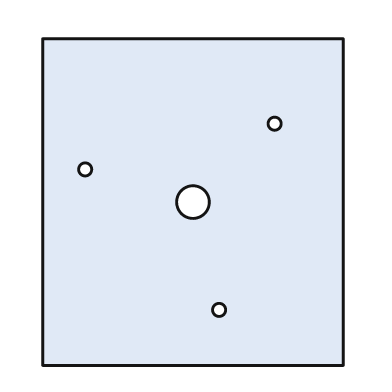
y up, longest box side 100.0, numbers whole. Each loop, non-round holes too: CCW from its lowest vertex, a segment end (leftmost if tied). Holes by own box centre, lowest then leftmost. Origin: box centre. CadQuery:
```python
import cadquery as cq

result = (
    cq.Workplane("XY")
    .moveTo(-46.0, -50.0)
    .lineTo(46.0, -50.0)
    .lineTo(46.0, 50.0)
    .lineTo(-46.0, 50.0)
    .close()
    .moveTo(8.0, -33.0)
    .circle(2.0)
    .moveTo(0.0, 0.0)
    .circle(5.0)
    .moveTo(-33.0, 10.0)
    .circle(2.0)
    .moveTo(25.0, 24.0)
    .circle(2.0)
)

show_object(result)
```